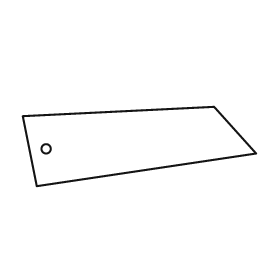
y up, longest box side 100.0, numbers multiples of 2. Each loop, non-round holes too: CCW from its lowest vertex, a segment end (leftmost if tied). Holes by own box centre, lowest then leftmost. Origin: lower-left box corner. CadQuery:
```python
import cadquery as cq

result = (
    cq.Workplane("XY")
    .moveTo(6.0, 0.0)
    .lineTo(100.0, 14.0)
    .lineTo(82.0, 34.0)
    .lineTo(0.0, 30.0)
    .close()
    .moveTo(10.0, 16.0)
    .circle(2.0)
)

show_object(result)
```